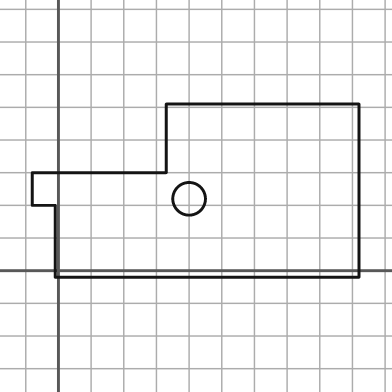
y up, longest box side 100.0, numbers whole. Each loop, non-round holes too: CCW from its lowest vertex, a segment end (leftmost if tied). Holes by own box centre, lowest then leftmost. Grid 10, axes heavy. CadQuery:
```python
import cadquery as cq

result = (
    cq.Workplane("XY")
    .moveTo(-1.0, -2.0)
    .lineTo(92.0, -2.0)
    .lineTo(92.0, 51.0)
    .lineTo(33.0, 51.0)
    .lineTo(33.0, 30.0)
    .lineTo(-8.0, 30.0)
    .lineTo(-8.0, 20.0)
    .lineTo(-1.0, 20.0)
    .close()
    .moveTo(40.0, 22.0)
    .circle(5.0)
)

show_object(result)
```